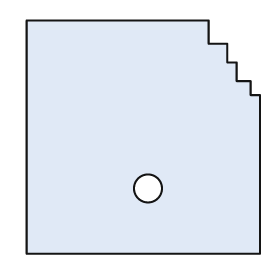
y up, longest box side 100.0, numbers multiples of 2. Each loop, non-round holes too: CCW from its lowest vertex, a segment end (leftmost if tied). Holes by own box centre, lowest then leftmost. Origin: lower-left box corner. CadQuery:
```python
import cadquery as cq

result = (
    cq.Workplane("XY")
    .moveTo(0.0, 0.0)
    .lineTo(100.0, 0.0)
    .lineTo(100.0, 68.0)
    .lineTo(96.0, 68.0)
    .lineTo(96.0, 74.0)
    .lineTo(90.0, 74.0)
    .lineTo(90.0, 82.0)
    .lineTo(86.0, 82.0)
    .lineTo(86.0, 90.0)
    .lineTo(78.0, 90.0)
    .lineTo(78.0, 100.0)
    .lineTo(0.0, 100.0)
    .close()
    .moveTo(52.0, 28.0)
    .circle(6.0)
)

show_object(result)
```